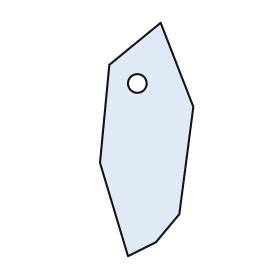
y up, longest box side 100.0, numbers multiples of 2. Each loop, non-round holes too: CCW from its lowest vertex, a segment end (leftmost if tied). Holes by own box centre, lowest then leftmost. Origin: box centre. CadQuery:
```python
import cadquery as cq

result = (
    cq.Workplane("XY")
    .moveTo(-8.0, -50.0)
    .lineTo(4.0, -44.0)
    .lineTo(14.0, -32.0)
    .lineTo(20.0, 14.0)
    .lineTo(6.0, 50.0)
    .lineTo(-16.0, 32.0)
    .lineTo(-20.0, -10.0)
    .close()
    .moveTo(-4.0, 24.0)
    .circle(4.0)
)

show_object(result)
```